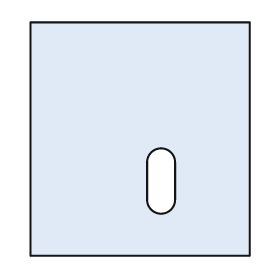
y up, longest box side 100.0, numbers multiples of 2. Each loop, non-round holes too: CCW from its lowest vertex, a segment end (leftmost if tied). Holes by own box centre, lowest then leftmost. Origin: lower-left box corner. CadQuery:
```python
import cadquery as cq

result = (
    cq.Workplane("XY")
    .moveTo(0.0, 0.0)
    .lineTo(94.0, 0.0)
    .lineTo(94.0, 100.0)
    .lineTo(0.0, 100.0)
    .close()
    .moveTo(50.0, 24.0)
    .threePointArc((56.0, 18.0), (62.0, 24.0))
    .lineTo(62.0, 40.0)
    .threePointArc((56.0, 46.0), (50.0, 40.0))
    .close()
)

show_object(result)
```